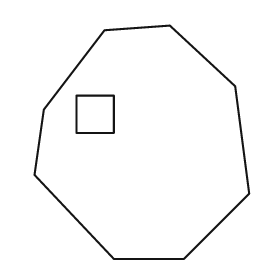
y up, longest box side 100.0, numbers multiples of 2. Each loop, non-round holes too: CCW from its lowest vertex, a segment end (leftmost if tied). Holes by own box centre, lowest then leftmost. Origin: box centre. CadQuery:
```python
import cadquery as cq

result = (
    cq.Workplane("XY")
    .moveTo(-12.0, -50.0)
    .lineTo(18.0, -50.0)
    .lineTo(46.0, -22.0)
    .lineTo(40.0, 24.0)
    .lineTo(12.0, 50.0)
    .lineTo(-16.0, 48.0)
    .lineTo(-42.0, 14.0)
    .lineTo(-46.0, -14.0)
    .close()
    .moveTo(-28.0, 4.0)
    .lineTo(-12.0, 4.0)
    .lineTo(-12.0, 20.0)
    .lineTo(-28.0, 20.0)
    .close()
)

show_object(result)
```